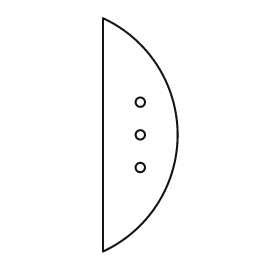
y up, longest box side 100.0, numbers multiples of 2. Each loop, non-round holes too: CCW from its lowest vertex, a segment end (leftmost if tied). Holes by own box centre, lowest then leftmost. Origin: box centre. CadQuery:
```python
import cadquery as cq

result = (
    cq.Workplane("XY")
    .moveTo(-16.0, -50.0)
    .threePointArc((16.0, 0.0), (-16.0, 50.0))
    .close()
    .moveTo(0.0, -14.0)
    .circle(2.0)
    .moveTo(0.0, 0.0)
    .circle(2.0)
    .moveTo(0.0, 14.0)
    .circle(2.0)
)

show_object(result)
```